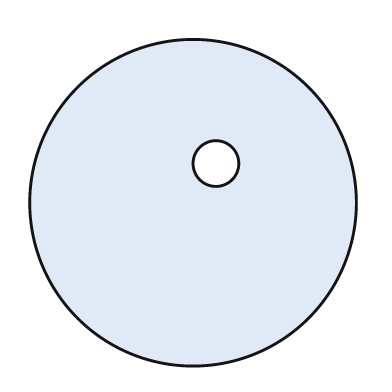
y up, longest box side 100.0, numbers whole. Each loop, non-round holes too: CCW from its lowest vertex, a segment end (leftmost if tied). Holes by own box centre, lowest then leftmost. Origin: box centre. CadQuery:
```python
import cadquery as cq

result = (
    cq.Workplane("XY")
    .moveTo(0.0, 0.0)
    .circle(50.0)
    .moveTo(7.0, 12.0)
    .circle(7.0)
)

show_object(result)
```